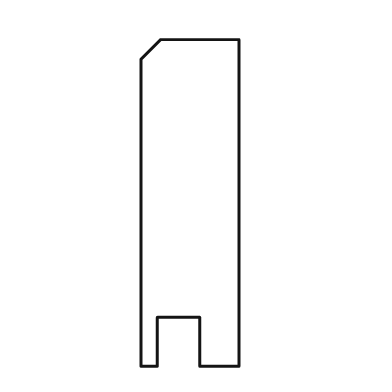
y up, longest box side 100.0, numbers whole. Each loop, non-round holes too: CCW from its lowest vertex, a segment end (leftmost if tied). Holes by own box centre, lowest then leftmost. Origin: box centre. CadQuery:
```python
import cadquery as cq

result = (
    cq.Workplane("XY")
    .moveTo(-15.0, -50.0)
    .lineTo(-10.0, -50.0)
    .lineTo(-10.0, -35.0)
    .lineTo(3.0, -35.0)
    .lineTo(3.0, -50.0)
    .lineTo(15.0, -50.0)
    .lineTo(15.0, 50.0)
    .lineTo(-9.0, 50.0)
    .lineTo(-15.0, 44.0)
    .close()
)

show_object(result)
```